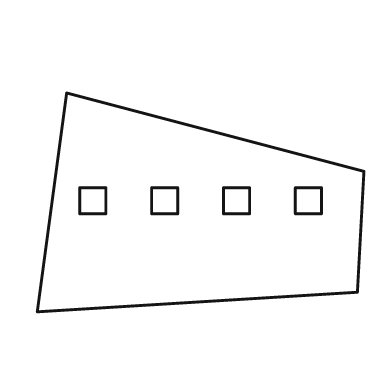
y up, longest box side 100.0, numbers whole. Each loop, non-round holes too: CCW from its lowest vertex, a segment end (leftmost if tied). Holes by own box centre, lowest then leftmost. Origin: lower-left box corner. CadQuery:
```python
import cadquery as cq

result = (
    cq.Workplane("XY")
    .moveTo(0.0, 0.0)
    .lineTo(98.0, 6.0)
    .lineTo(100.0, 43.0)
    .lineTo(9.0, 67.0)
    .close()
    .moveTo(13.0, 30.0)
    .lineTo(21.0, 30.0)
    .lineTo(21.0, 38.0)
    .lineTo(13.0, 38.0)
    .close()
    .moveTo(35.0, 30.0)
    .lineTo(43.0, 30.0)
    .lineTo(43.0, 38.0)
    .lineTo(35.0, 38.0)
    .close()
    .moveTo(57.0, 30.0)
    .lineTo(65.0, 30.0)
    .lineTo(65.0, 38.0)
    .lineTo(57.0, 38.0)
    .close()
    .moveTo(79.0, 30.0)
    .lineTo(87.0, 30.0)
    .lineTo(87.0, 38.0)
    .lineTo(79.0, 38.0)
    .close()
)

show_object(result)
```